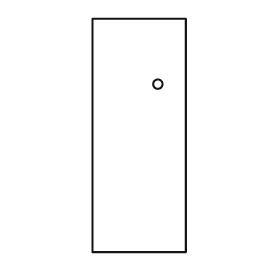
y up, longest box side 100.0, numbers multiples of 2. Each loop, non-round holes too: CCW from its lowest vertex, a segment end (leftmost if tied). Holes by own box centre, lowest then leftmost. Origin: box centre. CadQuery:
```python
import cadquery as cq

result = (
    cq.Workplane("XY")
    .moveTo(-20.0, -50.0)
    .lineTo(20.0, -50.0)
    .lineTo(20.0, 50.0)
    .lineTo(-20.0, 50.0)
    .close()
    .moveTo(8.0, 22.0)
    .circle(2.0)
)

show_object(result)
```